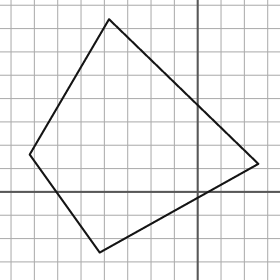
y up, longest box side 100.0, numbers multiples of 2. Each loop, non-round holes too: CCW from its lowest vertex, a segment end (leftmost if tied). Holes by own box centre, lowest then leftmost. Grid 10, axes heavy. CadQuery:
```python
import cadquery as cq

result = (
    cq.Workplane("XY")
    .moveTo(-42.0, -26.0)
    .lineTo(26.0, 12.0)
    .lineTo(-38.0, 74.0)
    .lineTo(-72.0, 16.0)
    .close()
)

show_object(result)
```